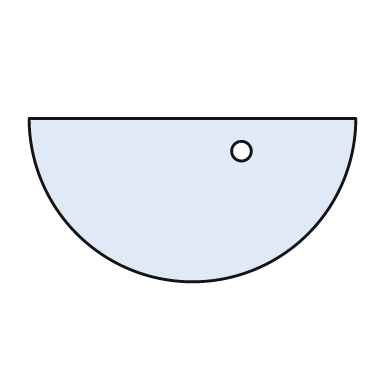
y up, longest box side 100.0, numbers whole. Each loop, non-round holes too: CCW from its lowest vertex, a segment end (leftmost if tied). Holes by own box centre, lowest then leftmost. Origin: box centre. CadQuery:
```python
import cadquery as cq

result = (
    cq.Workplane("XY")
    .moveTo(-50.0, 25.0)
    .threePointArc((0.0, -25.0), (50.0, 25.0))
    .close()
    .moveTo(15.0, 15.0)
    .circle(3.0)
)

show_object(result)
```